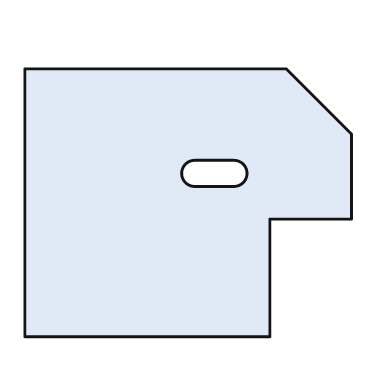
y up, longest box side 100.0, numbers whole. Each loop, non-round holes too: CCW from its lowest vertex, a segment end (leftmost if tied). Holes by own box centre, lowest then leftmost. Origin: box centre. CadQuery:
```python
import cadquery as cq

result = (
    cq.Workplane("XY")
    .moveTo(-50.0, -41.0)
    .lineTo(25.0, -41.0)
    .lineTo(25.0, -5.0)
    .lineTo(50.0, -5.0)
    .lineTo(50.0, 21.0)
    .lineTo(30.0, 41.0)
    .lineTo(-50.0, 41.0)
    .close()
    .moveTo(2.0, 5.0)
    .lineTo(14.0, 5.0)
    .threePointArc((18.0, 9.0), (14.0, 13.0))
    .lineTo(2.0, 13.0)
    .threePointArc((-2.0, 9.0), (2.0, 5.0))
    .close()
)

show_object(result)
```